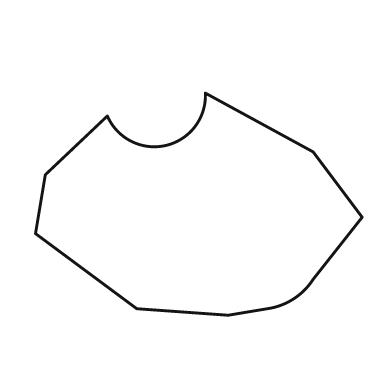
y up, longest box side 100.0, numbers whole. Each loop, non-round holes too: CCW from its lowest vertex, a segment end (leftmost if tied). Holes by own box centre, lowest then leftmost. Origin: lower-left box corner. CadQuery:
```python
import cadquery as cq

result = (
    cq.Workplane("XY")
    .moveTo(59.0, 0.0)
    .lineTo(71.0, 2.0)
    .threePointArc((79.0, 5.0), (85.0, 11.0))
    .lineTo(100.0, 30.0)
    .lineTo(85.0, 50.0)
    .lineTo(52.0, 68.0)
    .threePointArc((40.0, 52.0), (22.0, 61.0))
    .lineTo(3.0, 43.0)
    .lineTo(0.0, 25.0)
    .lineTo(31.0, 2.0)
    .close()
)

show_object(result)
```